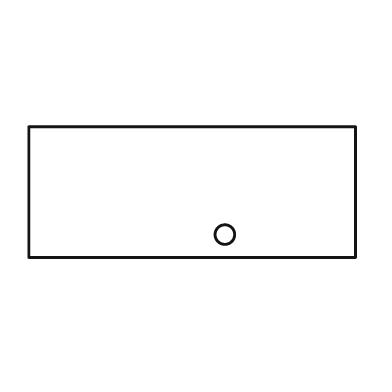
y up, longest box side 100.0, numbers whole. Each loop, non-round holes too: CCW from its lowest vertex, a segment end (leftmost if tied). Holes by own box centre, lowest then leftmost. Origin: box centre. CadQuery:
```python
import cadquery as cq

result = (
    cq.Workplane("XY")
    .moveTo(-50.0, -20.0)
    .lineTo(50.0, -20.0)
    .lineTo(50.0, 20.0)
    .lineTo(-50.0, 20.0)
    .close()
    .moveTo(10.0, -13.0)
    .circle(3.0)
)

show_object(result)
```